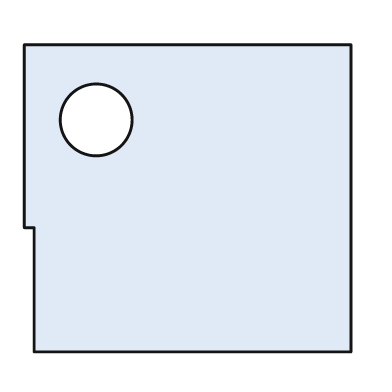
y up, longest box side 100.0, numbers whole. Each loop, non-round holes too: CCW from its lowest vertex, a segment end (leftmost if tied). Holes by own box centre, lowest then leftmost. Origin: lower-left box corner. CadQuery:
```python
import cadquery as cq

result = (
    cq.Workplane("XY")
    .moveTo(3.0, 0.0)
    .lineTo(100.0, 0.0)
    .lineTo(100.0, 94.0)
    .lineTo(0.0, 94.0)
    .lineTo(0.0, 38.0)
    .lineTo(3.0, 38.0)
    .close()
    .moveTo(22.0, 71.0)
    .circle(11.0)
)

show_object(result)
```